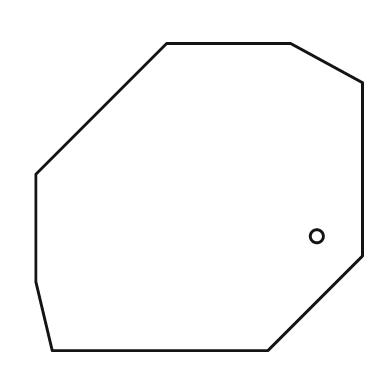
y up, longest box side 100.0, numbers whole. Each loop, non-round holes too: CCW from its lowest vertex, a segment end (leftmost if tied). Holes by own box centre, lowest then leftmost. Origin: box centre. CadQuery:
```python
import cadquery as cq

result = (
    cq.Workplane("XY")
    .moveTo(-45.0, -47.0)
    .lineTo(21.0, -47.0)
    .lineTo(50.0, -18.0)
    .lineTo(50.0, 35.0)
    .lineTo(28.0, 47.0)
    .lineTo(-10.0, 47.0)
    .lineTo(-50.0, 7.0)
    .lineTo(-50.0, -26.0)
    .close()
    .moveTo(36.0, -12.0)
    .circle(2.0)
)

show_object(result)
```